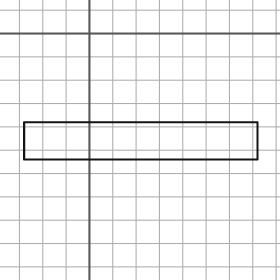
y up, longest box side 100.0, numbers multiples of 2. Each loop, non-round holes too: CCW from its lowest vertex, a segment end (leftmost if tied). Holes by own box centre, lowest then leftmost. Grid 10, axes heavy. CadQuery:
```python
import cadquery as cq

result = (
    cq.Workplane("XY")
    .moveTo(-28.0, -54.0)
    .lineTo(72.0, -54.0)
    .lineTo(72.0, -38.0)
    .lineTo(-28.0, -38.0)
    .close()
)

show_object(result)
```